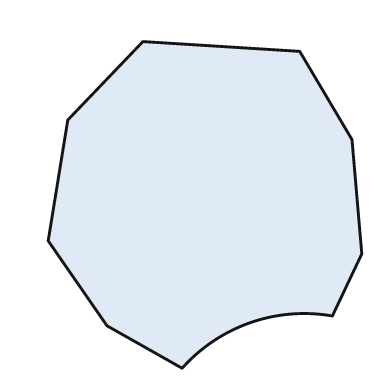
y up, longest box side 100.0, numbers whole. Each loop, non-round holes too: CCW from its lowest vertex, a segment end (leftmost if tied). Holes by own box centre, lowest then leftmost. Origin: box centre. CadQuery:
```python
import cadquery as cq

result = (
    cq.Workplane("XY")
    .moveTo(-7.0, -50.0)
    .threePointArc((14.0, -36.0), (39.0, -34.0))
    .lineTo(48.0, -15.0)
    .lineTo(45.0, 20.0)
    .lineTo(29.0, 47.0)
    .lineTo(-19.0, 50.0)
    .lineTo(-42.0, 26.0)
    .lineTo(-48.0, -11.0)
    .lineTo(-30.0, -37.0)
    .close()
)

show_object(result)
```